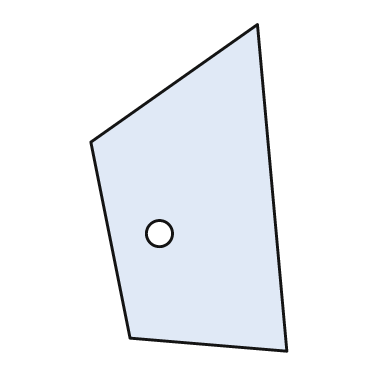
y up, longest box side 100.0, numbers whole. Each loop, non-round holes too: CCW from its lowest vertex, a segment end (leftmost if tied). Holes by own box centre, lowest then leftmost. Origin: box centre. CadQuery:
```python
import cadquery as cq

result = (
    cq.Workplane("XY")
    .moveTo(30.0, -50.0)
    .lineTo(21.0, 50.0)
    .lineTo(-30.0, 14.0)
    .lineTo(-18.0, -46.0)
    .close()
    .moveTo(-9.0, -14.0)
    .circle(4.0)
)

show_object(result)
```